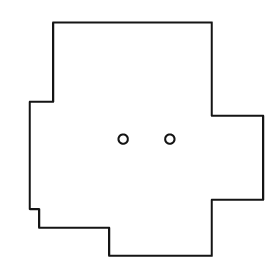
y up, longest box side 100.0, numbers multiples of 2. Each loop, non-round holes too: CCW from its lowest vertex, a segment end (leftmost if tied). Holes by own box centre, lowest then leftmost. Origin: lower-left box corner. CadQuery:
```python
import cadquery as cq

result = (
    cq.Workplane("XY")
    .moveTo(34.0, 0.0)
    .lineTo(78.0, 0.0)
    .lineTo(78.0, 24.0)
    .lineTo(100.0, 24.0)
    .lineTo(100.0, 60.0)
    .lineTo(78.0, 60.0)
    .lineTo(78.0, 100.0)
    .lineTo(10.0, 100.0)
    .lineTo(10.0, 66.0)
    .lineTo(0.0, 66.0)
    .lineTo(0.0, 20.0)
    .lineTo(4.0, 20.0)
    .lineTo(4.0, 12.0)
    .lineTo(34.0, 12.0)
    .close()
    .moveTo(40.0, 50.0)
    .circle(2.0)
    .moveTo(60.0, 50.0)
    .circle(2.0)
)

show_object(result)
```